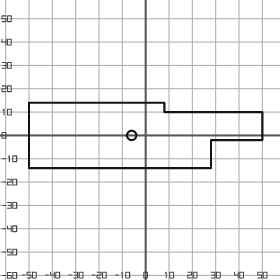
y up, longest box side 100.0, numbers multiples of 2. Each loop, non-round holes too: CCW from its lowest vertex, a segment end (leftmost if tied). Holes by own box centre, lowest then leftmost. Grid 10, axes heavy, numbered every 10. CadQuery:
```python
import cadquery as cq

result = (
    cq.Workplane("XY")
    .moveTo(-50.0, -14.0)
    .lineTo(28.0, -14.0)
    .lineTo(28.0, -2.0)
    .lineTo(50.0, -2.0)
    .lineTo(50.0, 10.0)
    .lineTo(8.0, 10.0)
    .lineTo(8.0, 14.0)
    .lineTo(-50.0, 14.0)
    .close()
    .moveTo(-6.0, 0.0)
    .circle(2.0)
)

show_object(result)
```